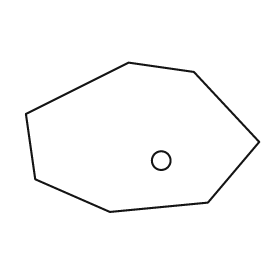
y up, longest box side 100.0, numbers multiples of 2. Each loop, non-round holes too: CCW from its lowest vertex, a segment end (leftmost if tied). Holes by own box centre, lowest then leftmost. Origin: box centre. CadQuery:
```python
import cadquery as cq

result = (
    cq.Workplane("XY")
    .moveTo(-14.0, -32.0)
    .lineTo(28.0, -28.0)
    .lineTo(50.0, -2.0)
    .lineTo(22.0, 28.0)
    .lineTo(-6.0, 32.0)
    .lineTo(-50.0, 10.0)
    .lineTo(-46.0, -18.0)
    .close()
    .moveTo(8.0, -10.0)
    .circle(4.0)
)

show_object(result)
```